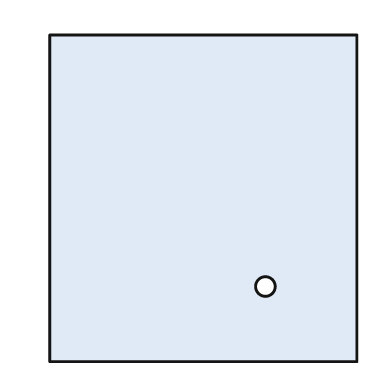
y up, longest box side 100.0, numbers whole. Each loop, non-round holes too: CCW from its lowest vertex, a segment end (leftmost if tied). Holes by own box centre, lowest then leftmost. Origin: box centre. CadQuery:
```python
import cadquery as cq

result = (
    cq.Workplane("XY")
    .moveTo(-47.0, -50.0)
    .lineTo(47.0, -50.0)
    .lineTo(47.0, 50.0)
    .lineTo(-47.0, 50.0)
    .close()
    .moveTo(19.0, -27.0)
    .circle(3.0)
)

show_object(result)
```